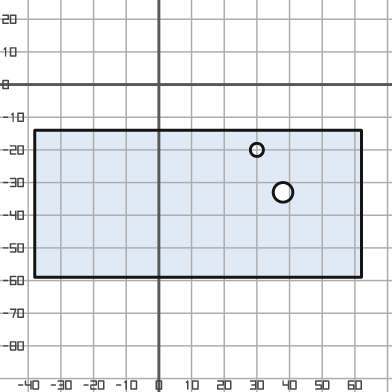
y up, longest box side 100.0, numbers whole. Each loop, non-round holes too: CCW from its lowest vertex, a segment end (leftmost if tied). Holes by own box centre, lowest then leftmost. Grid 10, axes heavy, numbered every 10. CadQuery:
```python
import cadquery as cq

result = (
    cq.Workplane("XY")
    .moveTo(-38.0, -59.0)
    .lineTo(62.0, -59.0)
    .lineTo(62.0, -14.0)
    .lineTo(-38.0, -14.0)
    .close()
    .moveTo(38.0, -33.0)
    .circle(3.0)
    .moveTo(30.0, -20.0)
    .circle(2.0)
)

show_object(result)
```